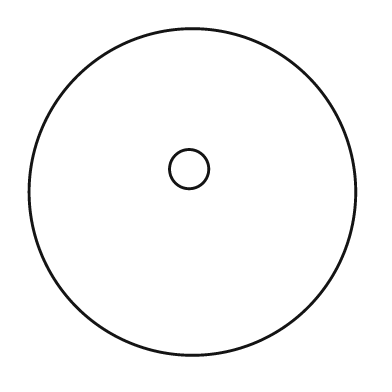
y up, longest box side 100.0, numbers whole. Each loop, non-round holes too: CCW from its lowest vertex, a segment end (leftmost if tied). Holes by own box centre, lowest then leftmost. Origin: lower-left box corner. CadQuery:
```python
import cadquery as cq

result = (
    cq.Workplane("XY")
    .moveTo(50.0, 50.0)
    .circle(50.0)
    .moveTo(49.0, 57.0)
    .circle(6.0)
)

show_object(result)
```